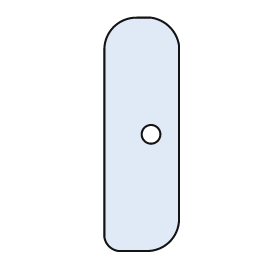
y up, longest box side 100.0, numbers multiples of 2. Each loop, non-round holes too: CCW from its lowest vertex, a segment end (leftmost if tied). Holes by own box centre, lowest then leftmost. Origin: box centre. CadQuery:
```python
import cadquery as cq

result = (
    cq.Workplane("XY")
    .moveTo(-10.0, -50.0)
    .lineTo(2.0, -50.0)
    .threePointArc((12.0, -46.0), (16.0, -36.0))
    .lineTo(16.0, 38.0)
    .threePointArc((12.0, 46.0), (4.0, 50.0))
    .lineTo(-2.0, 50.0)
    .threePointArc((-12.0, 46.0), (-16.0, 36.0))
    .lineTo(-16.0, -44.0)
    .threePointArc((-14.0, -48.0), (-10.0, -50.0))
    .close()
    .moveTo(4.0, 0.0)
    .circle(4.0)
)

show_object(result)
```